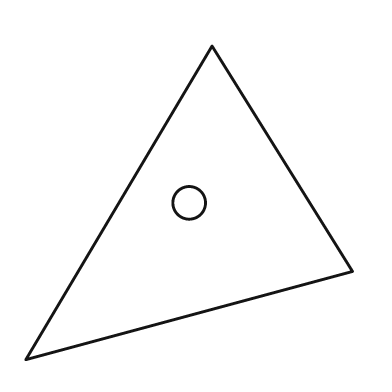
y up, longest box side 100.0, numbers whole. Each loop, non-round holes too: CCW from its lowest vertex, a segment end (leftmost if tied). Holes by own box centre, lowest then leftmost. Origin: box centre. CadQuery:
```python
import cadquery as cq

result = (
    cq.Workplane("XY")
    .moveTo(-50.0, -48.0)
    .lineTo(50.0, -21.0)
    .lineTo(7.0, 48.0)
    .close()
    .moveTo(0.0, 0.0)
    .circle(5.0)
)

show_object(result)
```